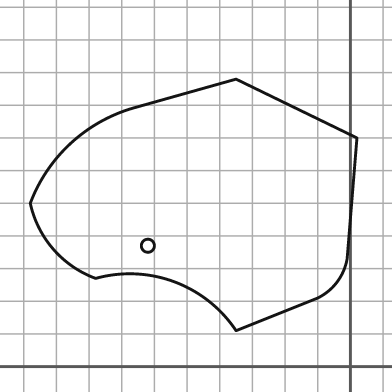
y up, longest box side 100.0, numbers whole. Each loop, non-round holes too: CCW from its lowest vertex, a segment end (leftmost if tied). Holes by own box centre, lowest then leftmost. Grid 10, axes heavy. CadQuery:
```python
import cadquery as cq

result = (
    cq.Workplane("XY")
    .moveTo(-35.0, 11.0)
    .lineTo(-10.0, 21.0)
    .threePointArc((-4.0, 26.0), (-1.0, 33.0))
    .lineTo(2.0, 70.0)
    .lineTo(-35.0, 88.0)
    .lineTo(-67.0, 79.0)
    .threePointArc((-86.0, 68.0), (-98.0, 50.0))
    .threePointArc((-91.0, 36.0), (-78.0, 27.0))
    .threePointArc((-54.0, 26.0), (-35.0, 11.0))
    .close()
    .moveTo(-62.0, 37.0)
    .circle(2.0)
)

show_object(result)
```